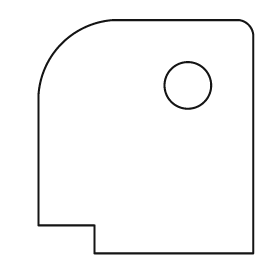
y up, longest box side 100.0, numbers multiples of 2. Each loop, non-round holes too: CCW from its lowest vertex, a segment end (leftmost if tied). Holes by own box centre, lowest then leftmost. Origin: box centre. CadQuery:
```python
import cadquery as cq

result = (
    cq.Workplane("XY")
    .moveTo(-22.0, -50.0)
    .lineTo(46.0, -50.0)
    .lineTo(46.0, 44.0)
    .threePointArc((44.0, 48.0), (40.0, 50.0))
    .lineTo(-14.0, 50.0)
    .threePointArc((-36.0, 40.0), (-46.0, 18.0))
    .lineTo(-46.0, -38.0)
    .lineTo(-22.0, -38.0)
    .close()
    .moveTo(18.0, 22.0)
    .circle(10.0)
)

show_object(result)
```